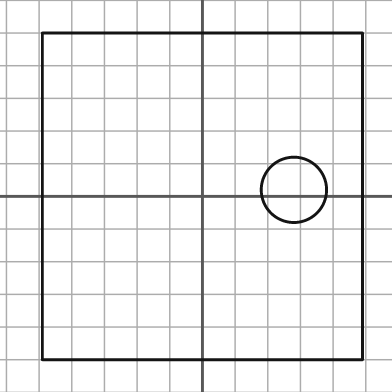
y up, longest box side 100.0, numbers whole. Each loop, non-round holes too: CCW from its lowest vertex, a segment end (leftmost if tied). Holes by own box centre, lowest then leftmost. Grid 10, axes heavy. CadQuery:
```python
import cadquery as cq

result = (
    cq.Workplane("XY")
    .moveTo(-49.0, -50.0)
    .lineTo(49.0, -50.0)
    .lineTo(49.0, 50.0)
    .lineTo(-49.0, 50.0)
    .close()
    .moveTo(28.0, 2.0)
    .circle(10.0)
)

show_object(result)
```